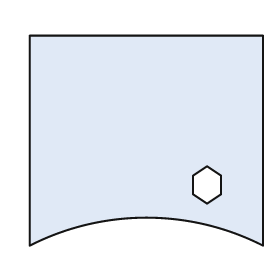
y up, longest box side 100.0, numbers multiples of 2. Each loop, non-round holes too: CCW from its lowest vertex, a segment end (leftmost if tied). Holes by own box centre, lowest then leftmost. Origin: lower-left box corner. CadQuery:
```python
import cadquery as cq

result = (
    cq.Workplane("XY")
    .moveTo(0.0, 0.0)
    .threePointArc((50.0, 12.0), (100.0, 0.0))
    .lineTo(100.0, 90.0)
    .lineTo(0.0, 90.0)
    .close()
    .moveTo(76.0, 18.0)
    .lineTo(82.0, 22.0)
    .lineTo(82.0, 30.0)
    .lineTo(76.0, 34.0)
    .lineTo(70.0, 30.0)
    .lineTo(70.0, 22.0)
    .close()
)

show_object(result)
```